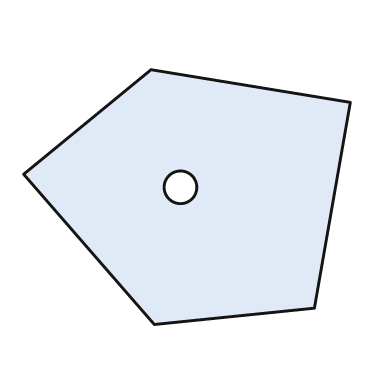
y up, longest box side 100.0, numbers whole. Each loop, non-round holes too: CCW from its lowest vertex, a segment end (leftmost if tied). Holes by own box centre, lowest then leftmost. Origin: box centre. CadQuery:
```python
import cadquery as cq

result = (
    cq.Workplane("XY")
    .moveTo(-10.0, -39.0)
    .lineTo(39.0, -34.0)
    .lineTo(50.0, 29.0)
    .lineTo(-11.0, 39.0)
    .lineTo(-50.0, 7.0)
    .close()
    .moveTo(-2.0, 3.0)
    .circle(5.0)
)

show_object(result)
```